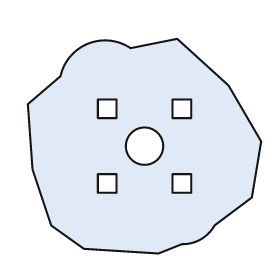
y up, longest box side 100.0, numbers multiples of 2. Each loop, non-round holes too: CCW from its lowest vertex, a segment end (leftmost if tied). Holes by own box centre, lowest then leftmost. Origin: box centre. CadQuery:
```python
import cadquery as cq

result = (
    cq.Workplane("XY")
    .moveTo(6.0, -46.0)
    .lineTo(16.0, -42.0)
    .threePointArc((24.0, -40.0), (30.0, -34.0))
    .lineTo(46.0, -22.0)
    .lineTo(50.0, 2.0)
    .lineTo(36.0, 26.0)
    .lineTo(14.0, 46.0)
    .lineTo(-6.0, 42.0)
    .threePointArc((-24.0, 44.0), (-36.0, 30.0))
    .lineTo(-50.0, 18.0)
    .lineTo(-48.0, -10.0)
    .lineTo(-40.0, -34.0)
    .lineTo(-26.0, -44.0)
    .close()
    .moveTo(-20.0, -20.0)
    .lineTo(-12.0, -20.0)
    .lineTo(-12.0, -12.0)
    .lineTo(-20.0, -12.0)
    .close()
    .moveTo(12.0, -20.0)
    .lineTo(20.0, -20.0)
    .lineTo(20.0, -12.0)
    .lineTo(12.0, -12.0)
    .close()
    .moveTo(0.0, 0.0)
    .circle(8.0)
    .moveTo(-20.0, 12.0)
    .lineTo(-12.0, 12.0)
    .lineTo(-12.0, 20.0)
    .lineTo(-20.0, 20.0)
    .close()
    .moveTo(12.0, 12.0)
    .lineTo(20.0, 12.0)
    .lineTo(20.0, 20.0)
    .lineTo(12.0, 20.0)
    .close()
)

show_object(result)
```